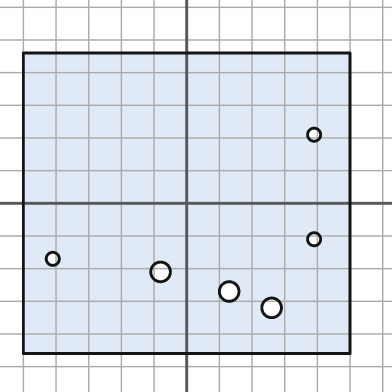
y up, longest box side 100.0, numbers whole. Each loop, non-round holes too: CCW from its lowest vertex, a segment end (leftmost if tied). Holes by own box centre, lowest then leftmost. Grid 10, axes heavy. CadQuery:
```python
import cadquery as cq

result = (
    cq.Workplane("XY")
    .moveTo(-50.0, -46.0)
    .lineTo(50.0, -46.0)
    .lineTo(50.0, 46.0)
    .lineTo(-50.0, 46.0)
    .close()
    .moveTo(26.0, -32.0)
    .circle(3.0)
    .moveTo(13.0, -27.0)
    .circle(3.0)
    .moveTo(-8.0, -21.0)
    .circle(3.0)
    .moveTo(-41.0, -17.0)
    .circle(2.0)
    .moveTo(39.0, -11.0)
    .circle(2.0)
    .moveTo(39.0, 21.0)
    .circle(2.0)
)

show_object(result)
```